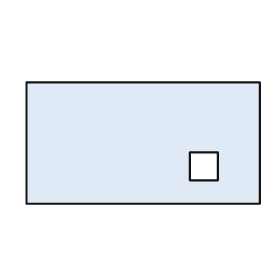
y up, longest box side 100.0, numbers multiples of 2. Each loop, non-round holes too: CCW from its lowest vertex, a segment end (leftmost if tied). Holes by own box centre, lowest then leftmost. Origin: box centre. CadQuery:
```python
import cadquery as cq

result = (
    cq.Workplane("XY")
    .moveTo(-50.0, -26.0)
    .lineTo(50.0, -26.0)
    .lineTo(50.0, 26.0)
    .lineTo(-50.0, 26.0)
    .close()
    .moveTo(20.0, -16.0)
    .lineTo(32.0, -16.0)
    .lineTo(32.0, -4.0)
    .lineTo(20.0, -4.0)
    .close()
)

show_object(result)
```